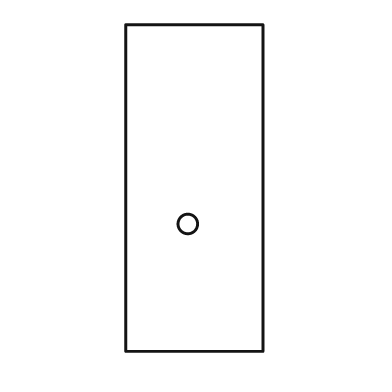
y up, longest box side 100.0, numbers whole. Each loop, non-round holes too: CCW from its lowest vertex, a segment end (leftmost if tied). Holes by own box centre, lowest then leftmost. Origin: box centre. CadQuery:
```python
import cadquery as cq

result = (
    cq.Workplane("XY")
    .moveTo(-21.0, -50.0)
    .lineTo(21.0, -50.0)
    .lineTo(21.0, 50.0)
    .lineTo(-21.0, 50.0)
    .close()
    .moveTo(-2.0, -11.0)
    .circle(3.0)
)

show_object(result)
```